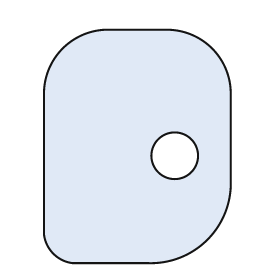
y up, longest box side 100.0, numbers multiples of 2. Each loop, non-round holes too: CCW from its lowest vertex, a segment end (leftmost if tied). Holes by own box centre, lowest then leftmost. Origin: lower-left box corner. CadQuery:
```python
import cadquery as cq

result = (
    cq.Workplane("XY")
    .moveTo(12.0, 0.0)
    .lineTo(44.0, 0.0)
    .threePointArc((70.0, 10.0), (80.0, 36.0))
    .lineTo(80.0, 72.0)
    .threePointArc((72.0, 92.0), (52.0, 100.0))
    .lineTo(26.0, 100.0)
    .threePointArc((8.0, 92.0), (0.0, 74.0))
    .lineTo(0.0, 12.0)
    .threePointArc((4.0, 4.0), (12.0, 0.0))
    .close()
    .moveTo(56.0, 46.0)
    .circle(10.0)
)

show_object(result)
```